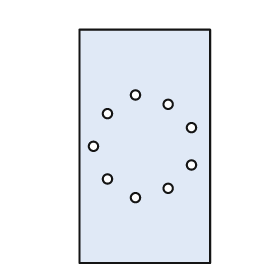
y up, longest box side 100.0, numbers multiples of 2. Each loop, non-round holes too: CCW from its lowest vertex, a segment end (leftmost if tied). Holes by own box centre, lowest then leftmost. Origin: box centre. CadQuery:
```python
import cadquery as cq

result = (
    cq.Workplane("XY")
    .moveTo(-28.0, -50.0)
    .lineTo(28.0, -50.0)
    .lineTo(28.0, 50.0)
    .lineTo(-28.0, 50.0)
    .close()
    .moveTo(-4.0, -22.0)
    .circle(2.0)
    .moveTo(10.0, -18.0)
    .circle(2.0)
    .moveTo(-16.0, -14.0)
    .circle(2.0)
    .moveTo(20.0, -8.0)
    .circle(2.0)
    .moveTo(-22.0, 0.0)
    .circle(2.0)
    .moveTo(20.0, 8.0)
    .circle(2.0)
    .moveTo(-16.0, 14.0)
    .circle(2.0)
    .moveTo(10.0, 18.0)
    .circle(2.0)
    .moveTo(-4.0, 22.0)
    .circle(2.0)
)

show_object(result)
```